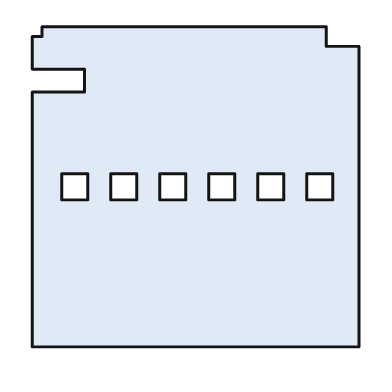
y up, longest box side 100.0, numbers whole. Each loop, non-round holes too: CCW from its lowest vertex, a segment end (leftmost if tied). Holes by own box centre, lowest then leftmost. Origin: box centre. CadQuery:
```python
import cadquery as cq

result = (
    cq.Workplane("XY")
    .moveTo(-50.0, -49.0)
    .lineTo(50.0, -49.0)
    .lineTo(50.0, 43.0)
    .lineTo(40.0, 43.0)
    .lineTo(40.0, 49.0)
    .lineTo(-47.0, 49.0)
    .lineTo(-47.0, 46.0)
    .lineTo(-50.0, 46.0)
    .lineTo(-50.0, 36.0)
    .lineTo(-34.0, 36.0)
    .lineTo(-34.0, 29.0)
    .lineTo(-50.0, 29.0)
    .close()
    .moveTo(-41.0, -4.0)
    .lineTo(-33.0, -4.0)
    .lineTo(-33.0, 4.0)
    .lineTo(-41.0, 4.0)
    .close()
    .moveTo(-26.0, -4.0)
    .lineTo(-18.0, -4.0)
    .lineTo(-18.0, 4.0)
    .lineTo(-26.0, 4.0)
    .close()
    .moveTo(-11.0, -4.0)
    .lineTo(-3.0, -4.0)
    .lineTo(-3.0, 4.0)
    .lineTo(-11.0, 4.0)
    .close()
    .moveTo(4.0, -4.0)
    .lineTo(12.0, -4.0)
    .lineTo(12.0, 4.0)
    .lineTo(4.0, 4.0)
    .close()
    .moveTo(19.0, -4.0)
    .lineTo(27.0, -4.0)
    .lineTo(27.0, 4.0)
    .lineTo(19.0, 4.0)
    .close()
    .moveTo(34.0, -4.0)
    .lineTo(42.0, -4.0)
    .lineTo(42.0, 4.0)
    .lineTo(34.0, 4.0)
    .close()
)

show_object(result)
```